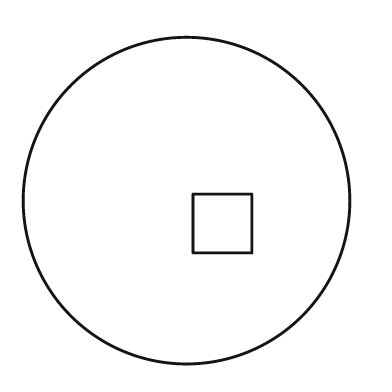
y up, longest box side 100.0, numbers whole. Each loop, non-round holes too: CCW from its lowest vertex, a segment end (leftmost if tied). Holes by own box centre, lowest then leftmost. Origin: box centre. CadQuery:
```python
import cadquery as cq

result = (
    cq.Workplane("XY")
    .moveTo(0.0, 0.0)
    .circle(50.0)
    .moveTo(2.0, -16.0)
    .lineTo(20.0, -16.0)
    .lineTo(20.0, 2.0)
    .lineTo(2.0, 2.0)
    .close()
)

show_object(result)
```